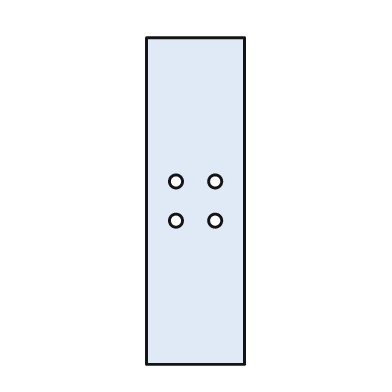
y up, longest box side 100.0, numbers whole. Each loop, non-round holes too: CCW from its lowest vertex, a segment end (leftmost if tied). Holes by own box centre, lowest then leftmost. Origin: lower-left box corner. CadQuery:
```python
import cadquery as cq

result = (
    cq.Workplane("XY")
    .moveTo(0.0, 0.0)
    .lineTo(30.0, 0.0)
    .lineTo(30.0, 100.0)
    .lineTo(0.0, 100.0)
    .close()
    .moveTo(9.0, 44.0)
    .circle(2.0)
    .moveTo(21.0, 44.0)
    .circle(2.0)
    .moveTo(9.0, 56.0)
    .circle(2.0)
    .moveTo(21.0, 56.0)
    .circle(2.0)
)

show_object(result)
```